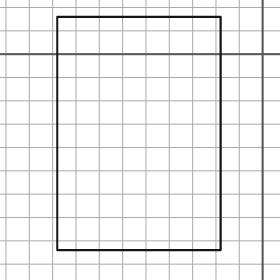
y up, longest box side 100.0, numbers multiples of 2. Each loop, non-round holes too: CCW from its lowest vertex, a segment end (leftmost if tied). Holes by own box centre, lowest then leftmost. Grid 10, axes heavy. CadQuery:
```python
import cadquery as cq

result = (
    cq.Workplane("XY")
    .moveTo(-88.0, -84.0)
    .lineTo(-18.0, -84.0)
    .lineTo(-18.0, 16.0)
    .lineTo(-88.0, 16.0)
    .close()
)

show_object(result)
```